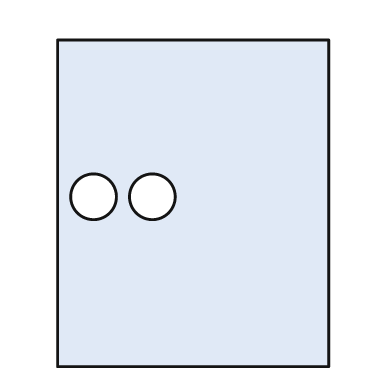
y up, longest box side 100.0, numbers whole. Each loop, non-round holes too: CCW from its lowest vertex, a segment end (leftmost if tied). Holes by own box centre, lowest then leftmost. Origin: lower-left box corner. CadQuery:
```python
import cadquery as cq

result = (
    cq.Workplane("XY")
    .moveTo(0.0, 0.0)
    .lineTo(83.0, 0.0)
    .lineTo(83.0, 100.0)
    .lineTo(0.0, 100.0)
    .close()
    .moveTo(11.0, 52.0)
    .circle(7.0)
    .moveTo(29.0, 52.0)
    .circle(7.0)
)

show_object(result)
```